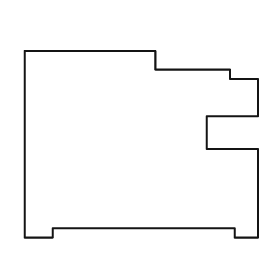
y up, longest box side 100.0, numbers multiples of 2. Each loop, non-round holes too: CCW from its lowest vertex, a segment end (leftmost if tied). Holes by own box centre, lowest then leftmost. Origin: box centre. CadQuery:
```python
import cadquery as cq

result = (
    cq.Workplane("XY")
    .moveTo(-50.0, -40.0)
    .lineTo(-38.0, -40.0)
    .lineTo(-38.0, -36.0)
    .lineTo(40.0, -36.0)
    .lineTo(40.0, -40.0)
    .lineTo(50.0, -40.0)
    .lineTo(50.0, -2.0)
    .lineTo(28.0, -2.0)
    .lineTo(28.0, 12.0)
    .lineTo(50.0, 12.0)
    .lineTo(50.0, 28.0)
    .lineTo(38.0, 28.0)
    .lineTo(38.0, 32.0)
    .lineTo(6.0, 32.0)
    .lineTo(6.0, 40.0)
    .lineTo(-50.0, 40.0)
    .close()
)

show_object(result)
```